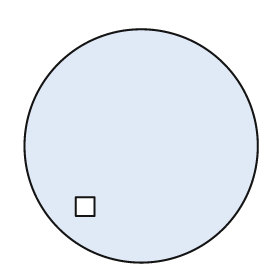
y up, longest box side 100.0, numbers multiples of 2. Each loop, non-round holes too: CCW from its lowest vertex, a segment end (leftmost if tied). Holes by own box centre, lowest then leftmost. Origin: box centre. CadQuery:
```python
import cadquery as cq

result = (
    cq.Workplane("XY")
    .moveTo(0.0, 0.0)
    .circle(50.0)
    .moveTo(-28.0, -30.0)
    .lineTo(-20.0, -30.0)
    .lineTo(-20.0, -22.0)
    .lineTo(-28.0, -22.0)
    .close()
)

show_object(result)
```